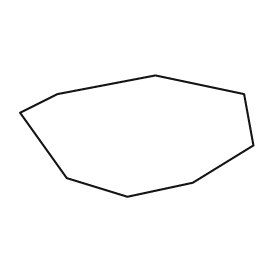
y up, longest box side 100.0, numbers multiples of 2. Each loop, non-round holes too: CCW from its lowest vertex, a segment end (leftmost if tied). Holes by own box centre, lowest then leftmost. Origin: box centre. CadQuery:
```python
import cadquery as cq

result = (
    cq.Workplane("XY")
    .moveTo(-4.0, -26.0)
    .lineTo(24.0, -20.0)
    .lineTo(50.0, -4.0)
    .lineTo(46.0, 18.0)
    .lineTo(8.0, 26.0)
    .lineTo(-34.0, 18.0)
    .lineTo(-50.0, 10.0)
    .lineTo(-30.0, -18.0)
    .close()
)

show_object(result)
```